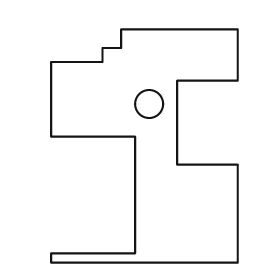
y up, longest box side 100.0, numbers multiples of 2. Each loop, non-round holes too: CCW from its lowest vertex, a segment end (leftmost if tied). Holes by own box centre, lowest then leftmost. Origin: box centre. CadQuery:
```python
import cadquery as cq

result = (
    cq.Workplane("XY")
    .moveTo(-40.0, -50.0)
    .lineTo(40.0, -50.0)
    .lineTo(40.0, -8.0)
    .lineTo(14.0, -8.0)
    .lineTo(14.0, 28.0)
    .lineTo(40.0, 28.0)
    .lineTo(40.0, 50.0)
    .lineTo(-10.0, 50.0)
    .lineTo(-10.0, 42.0)
    .lineTo(-18.0, 42.0)
    .lineTo(-18.0, 36.0)
    .lineTo(-40.0, 36.0)
    .lineTo(-40.0, 4.0)
    .lineTo(-4.0, 4.0)
    .lineTo(-4.0, -46.0)
    .lineTo(-40.0, -46.0)
    .close()
    .moveTo(2.0, 18.0)
    .circle(6.0)
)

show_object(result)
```